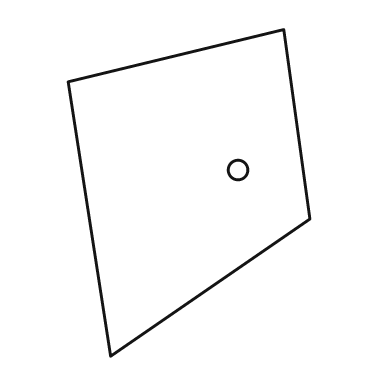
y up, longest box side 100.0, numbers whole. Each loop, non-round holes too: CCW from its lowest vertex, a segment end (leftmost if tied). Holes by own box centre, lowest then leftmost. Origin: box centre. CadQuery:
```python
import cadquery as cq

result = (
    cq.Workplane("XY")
    .moveTo(-24.0, -50.0)
    .lineTo(37.0, -8.0)
    .lineTo(29.0, 50.0)
    .lineTo(-37.0, 34.0)
    .close()
    .moveTo(15.0, 7.0)
    .circle(3.0)
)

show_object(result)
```